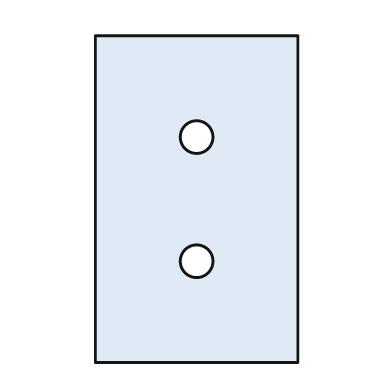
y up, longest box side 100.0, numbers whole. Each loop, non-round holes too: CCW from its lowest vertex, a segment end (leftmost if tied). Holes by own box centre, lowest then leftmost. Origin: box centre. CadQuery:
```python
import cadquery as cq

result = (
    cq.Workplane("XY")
    .moveTo(-31.0, -50.0)
    .lineTo(31.0, -50.0)
    .lineTo(31.0, 50.0)
    .lineTo(-31.0, 50.0)
    .close()
    .moveTo(0.0, -19.0)
    .circle(5.0)
    .moveTo(0.0, 19.0)
    .circle(5.0)
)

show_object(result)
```